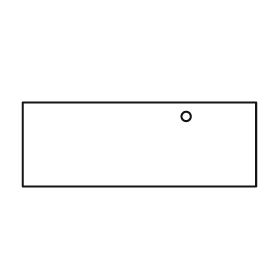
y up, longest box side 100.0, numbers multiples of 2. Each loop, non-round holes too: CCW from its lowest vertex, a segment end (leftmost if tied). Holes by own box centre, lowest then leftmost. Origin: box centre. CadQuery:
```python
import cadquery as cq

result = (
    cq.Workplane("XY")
    .moveTo(-50.0, -18.0)
    .lineTo(50.0, -18.0)
    .lineTo(50.0, 18.0)
    .lineTo(-50.0, 18.0)
    .close()
    .moveTo(20.0, 12.0)
    .circle(2.0)
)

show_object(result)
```